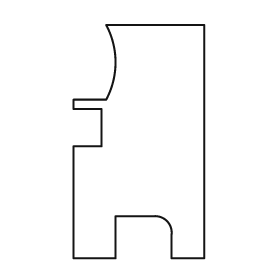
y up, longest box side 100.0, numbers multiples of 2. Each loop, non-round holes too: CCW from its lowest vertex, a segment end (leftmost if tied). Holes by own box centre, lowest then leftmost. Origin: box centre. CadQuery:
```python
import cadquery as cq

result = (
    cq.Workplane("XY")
    .moveTo(-28.0, -50.0)
    .lineTo(-10.0, -50.0)
    .lineTo(-10.0, -32.0)
    .lineTo(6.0, -32.0)
    .threePointArc((12.0, -34.0), (14.0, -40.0))
    .lineTo(14.0, -50.0)
    .lineTo(28.0, -50.0)
    .lineTo(28.0, 50.0)
    .lineTo(-14.0, 50.0)
    .threePointArc((-10.0, 34.0), (-14.0, 18.0))
    .lineTo(-28.0, 18.0)
    .lineTo(-28.0, 14.0)
    .lineTo(-16.0, 14.0)
    .lineTo(-16.0, -2.0)
    .lineTo(-28.0, -2.0)
    .close()
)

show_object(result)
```